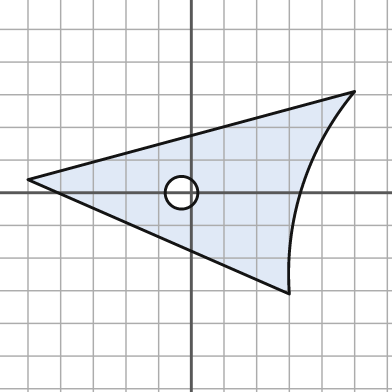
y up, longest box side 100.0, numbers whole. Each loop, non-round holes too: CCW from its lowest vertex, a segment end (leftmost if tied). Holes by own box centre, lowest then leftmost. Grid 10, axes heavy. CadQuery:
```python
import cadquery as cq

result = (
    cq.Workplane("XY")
    .moveTo(30.0, -31.0)
    .threePointArc((34.0, 2.0), (50.0, 31.0))
    .lineTo(-50.0, 4.0)
    .close()
    .moveTo(-3.0, 0.0)
    .circle(5.0)
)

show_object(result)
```